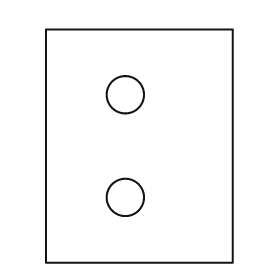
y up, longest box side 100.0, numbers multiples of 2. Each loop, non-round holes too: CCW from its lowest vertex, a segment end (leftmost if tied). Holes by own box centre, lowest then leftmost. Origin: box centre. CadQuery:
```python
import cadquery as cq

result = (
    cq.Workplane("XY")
    .moveTo(-40.0, -50.0)
    .lineTo(40.0, -50.0)
    .lineTo(40.0, 50.0)
    .lineTo(-40.0, 50.0)
    .close()
    .moveTo(-6.0, -22.0)
    .circle(8.0)
    .moveTo(-6.0, 22.0)
    .circle(8.0)
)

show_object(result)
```